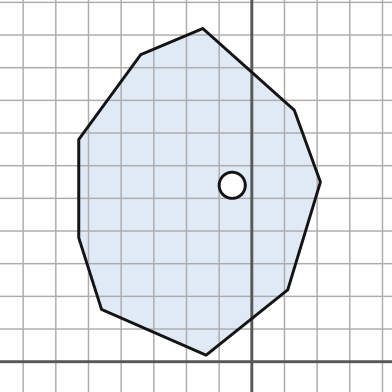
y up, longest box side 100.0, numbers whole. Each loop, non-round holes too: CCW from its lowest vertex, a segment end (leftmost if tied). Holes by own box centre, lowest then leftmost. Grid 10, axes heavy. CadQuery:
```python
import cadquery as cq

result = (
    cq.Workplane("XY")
    .moveTo(-14.0, 2.0)
    .lineTo(11.0, 22.0)
    .lineTo(21.0, 55.0)
    .lineTo(13.0, 77.0)
    .lineTo(-15.0, 102.0)
    .lineTo(-34.0, 94.0)
    .lineTo(-53.0, 68.0)
    .lineTo(-53.0, 38.0)
    .lineTo(-46.0, 16.0)
    .close()
    .moveTo(-6.0, 54.0)
    .circle(4.0)
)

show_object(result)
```